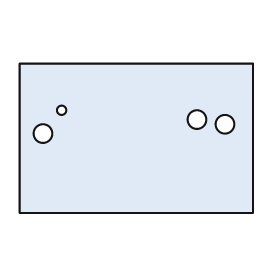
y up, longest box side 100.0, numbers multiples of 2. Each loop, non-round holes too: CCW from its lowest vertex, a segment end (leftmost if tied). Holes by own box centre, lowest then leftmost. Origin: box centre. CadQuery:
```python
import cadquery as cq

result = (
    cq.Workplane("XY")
    .moveTo(-50.0, -32.0)
    .lineTo(50.0, -32.0)
    .lineTo(50.0, 32.0)
    .lineTo(-50.0, 32.0)
    .close()
    .moveTo(-40.0, 2.0)
    .circle(4.0)
    .moveTo(38.0, 6.0)
    .circle(4.0)
    .moveTo(26.0, 8.0)
    .circle(4.0)
    .moveTo(-32.0, 12.0)
    .circle(2.0)
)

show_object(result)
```